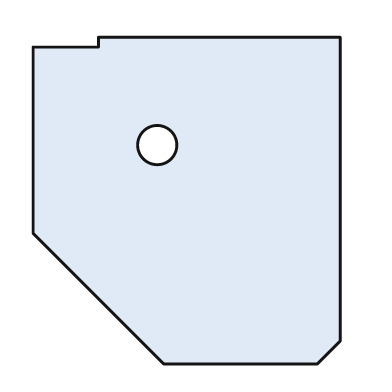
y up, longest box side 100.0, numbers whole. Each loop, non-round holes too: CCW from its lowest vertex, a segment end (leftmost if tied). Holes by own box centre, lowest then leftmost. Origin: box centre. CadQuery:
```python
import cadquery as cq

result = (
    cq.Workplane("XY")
    .moveTo(-7.0, -50.0)
    .lineTo(40.0, -50.0)
    .lineTo(47.0, -43.0)
    .lineTo(47.0, 50.0)
    .lineTo(-27.0, 50.0)
    .lineTo(-27.0, 47.0)
    .lineTo(-47.0, 47.0)
    .lineTo(-47.0, -10.0)
    .close()
    .moveTo(-9.0, 17.0)
    .circle(6.0)
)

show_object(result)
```